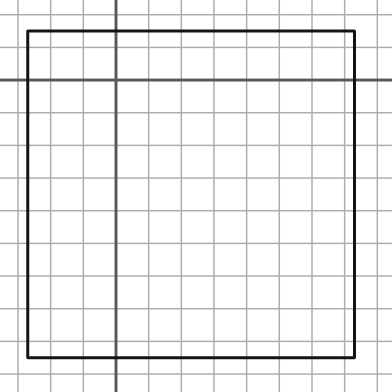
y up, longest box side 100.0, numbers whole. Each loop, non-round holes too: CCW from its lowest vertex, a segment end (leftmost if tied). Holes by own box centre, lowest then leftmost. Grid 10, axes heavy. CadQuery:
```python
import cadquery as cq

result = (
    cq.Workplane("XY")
    .moveTo(-27.0, -85.0)
    .lineTo(73.0, -85.0)
    .lineTo(73.0, 15.0)
    .lineTo(-27.0, 15.0)
    .close()
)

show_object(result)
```